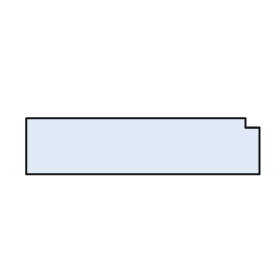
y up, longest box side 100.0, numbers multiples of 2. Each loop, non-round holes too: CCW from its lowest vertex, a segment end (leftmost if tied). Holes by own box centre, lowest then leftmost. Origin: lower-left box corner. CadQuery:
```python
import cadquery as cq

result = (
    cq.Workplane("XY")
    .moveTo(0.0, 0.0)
    .lineTo(100.0, 0.0)
    .lineTo(100.0, 20.0)
    .lineTo(94.0, 20.0)
    .lineTo(94.0, 24.0)
    .lineTo(0.0, 24.0)
    .close()
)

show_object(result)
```